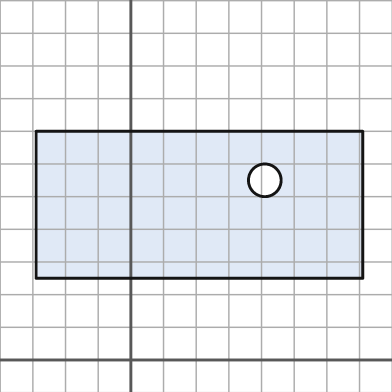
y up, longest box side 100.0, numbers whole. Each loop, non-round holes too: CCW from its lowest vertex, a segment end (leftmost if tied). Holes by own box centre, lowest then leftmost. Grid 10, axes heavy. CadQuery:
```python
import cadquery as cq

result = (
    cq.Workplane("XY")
    .moveTo(-29.0, 25.0)
    .lineTo(71.0, 25.0)
    .lineTo(71.0, 70.0)
    .lineTo(-29.0, 70.0)
    .close()
    .moveTo(41.0, 55.0)
    .circle(5.0)
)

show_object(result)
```